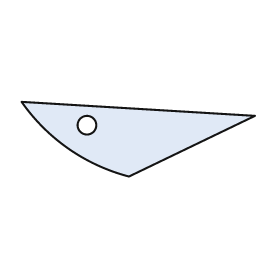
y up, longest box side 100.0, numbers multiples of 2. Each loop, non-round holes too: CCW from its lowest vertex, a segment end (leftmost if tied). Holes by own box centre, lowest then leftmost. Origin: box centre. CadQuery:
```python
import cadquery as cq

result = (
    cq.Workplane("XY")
    .moveTo(-4.0, -16.0)
    .lineTo(50.0, 10.0)
    .lineTo(-50.0, 16.0)
    .threePointArc((-30.0, -4.0), (-4.0, -16.0))
    .close()
    .moveTo(-22.0, 6.0)
    .circle(4.0)
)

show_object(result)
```